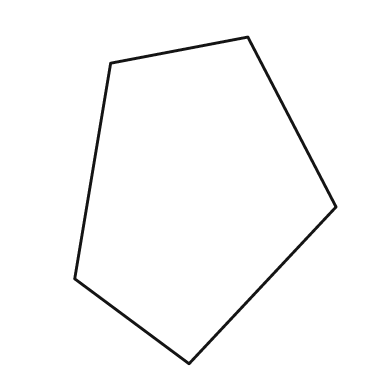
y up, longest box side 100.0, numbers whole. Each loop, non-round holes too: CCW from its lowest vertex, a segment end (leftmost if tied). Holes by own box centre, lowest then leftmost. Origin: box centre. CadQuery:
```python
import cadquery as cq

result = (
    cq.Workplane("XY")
    .moveTo(-5.0, -50.0)
    .lineTo(40.0, -2.0)
    .lineTo(13.0, 50.0)
    .lineTo(-29.0, 42.0)
    .lineTo(-40.0, -24.0)
    .close()
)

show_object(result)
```